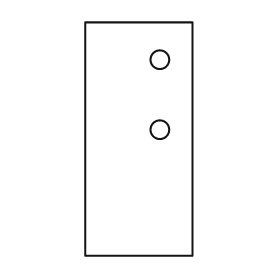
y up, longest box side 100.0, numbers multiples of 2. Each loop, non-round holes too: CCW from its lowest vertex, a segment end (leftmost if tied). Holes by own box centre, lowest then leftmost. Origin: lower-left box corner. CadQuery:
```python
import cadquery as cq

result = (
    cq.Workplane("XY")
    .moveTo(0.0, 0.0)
    .lineTo(46.0, 0.0)
    .lineTo(46.0, 100.0)
    .lineTo(0.0, 100.0)
    .close()
    .moveTo(32.0, 54.0)
    .circle(4.0)
    .moveTo(32.0, 84.0)
    .circle(4.0)
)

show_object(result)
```